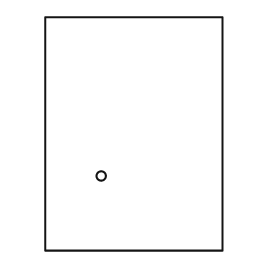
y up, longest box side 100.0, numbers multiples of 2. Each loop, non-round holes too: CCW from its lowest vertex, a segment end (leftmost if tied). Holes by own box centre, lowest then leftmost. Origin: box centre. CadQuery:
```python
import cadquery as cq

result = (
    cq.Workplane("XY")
    .moveTo(-38.0, -50.0)
    .lineTo(38.0, -50.0)
    .lineTo(38.0, 50.0)
    .lineTo(-38.0, 50.0)
    .close()
    .moveTo(-14.0, -18.0)
    .circle(2.0)
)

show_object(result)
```